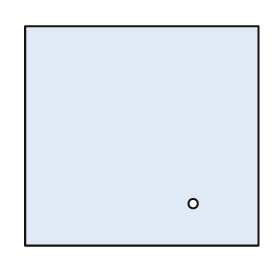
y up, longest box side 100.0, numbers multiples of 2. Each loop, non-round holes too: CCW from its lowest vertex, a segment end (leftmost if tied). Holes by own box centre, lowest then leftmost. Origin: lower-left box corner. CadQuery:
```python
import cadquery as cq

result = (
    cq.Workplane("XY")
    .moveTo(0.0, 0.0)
    .lineTo(100.0, 0.0)
    .lineTo(100.0, 94.0)
    .lineTo(0.0, 94.0)
    .close()
    .moveTo(72.0, 18.0)
    .circle(2.0)
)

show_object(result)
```